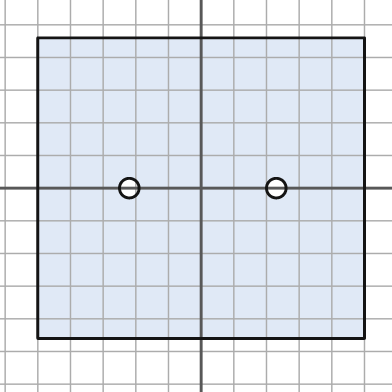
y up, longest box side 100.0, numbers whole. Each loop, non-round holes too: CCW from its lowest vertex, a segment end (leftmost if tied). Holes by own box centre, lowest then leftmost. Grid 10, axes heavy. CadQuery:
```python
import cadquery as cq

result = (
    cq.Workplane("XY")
    .moveTo(-50.0, -46.0)
    .lineTo(50.0, -46.0)
    .lineTo(50.0, 46.0)
    .lineTo(-50.0, 46.0)
    .close()
    .moveTo(-22.0, 0.0)
    .circle(3.0)
    .moveTo(23.0, 0.0)
    .circle(3.0)
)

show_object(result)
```